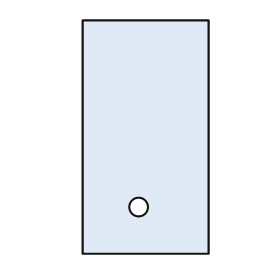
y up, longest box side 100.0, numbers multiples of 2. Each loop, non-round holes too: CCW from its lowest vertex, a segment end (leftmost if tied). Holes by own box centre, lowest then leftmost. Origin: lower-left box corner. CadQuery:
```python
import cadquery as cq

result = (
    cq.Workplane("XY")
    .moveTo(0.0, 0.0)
    .lineTo(54.0, 0.0)
    .lineTo(54.0, 100.0)
    .lineTo(0.0, 100.0)
    .close()
    .moveTo(24.0, 20.0)
    .circle(4.0)
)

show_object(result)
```